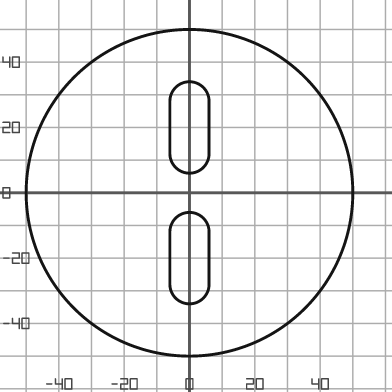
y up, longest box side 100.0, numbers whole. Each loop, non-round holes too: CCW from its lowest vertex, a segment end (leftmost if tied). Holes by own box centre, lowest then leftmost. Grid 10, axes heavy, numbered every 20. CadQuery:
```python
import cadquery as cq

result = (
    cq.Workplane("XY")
    .moveTo(0.0, 0.0)
    .circle(50.0)
    .moveTo(-6.0, -28.0)
    .threePointArc((0.0, -34.0), (6.0, -28.0))
    .lineTo(6.0, -12.0)
    .threePointArc((0.0, -6.0), (-6.0, -12.0))
    .close()
    .moveTo(-6.0, 12.0)
    .threePointArc((0.0, 6.0), (6.0, 12.0))
    .lineTo(6.0, 28.0)
    .threePointArc((0.0, 34.0), (-6.0, 28.0))
    .close()
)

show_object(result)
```